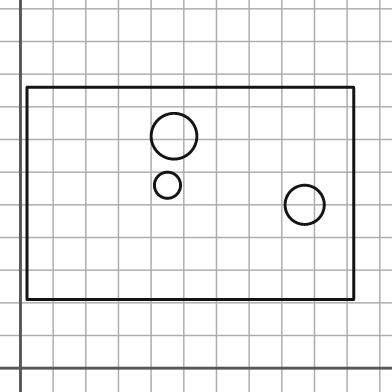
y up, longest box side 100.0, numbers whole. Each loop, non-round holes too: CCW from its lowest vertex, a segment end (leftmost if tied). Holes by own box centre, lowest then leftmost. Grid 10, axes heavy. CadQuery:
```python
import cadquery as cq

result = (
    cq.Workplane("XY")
    .moveTo(2.0, 21.0)
    .lineTo(102.0, 21.0)
    .lineTo(102.0, 86.0)
    .lineTo(2.0, 86.0)
    .close()
    .moveTo(87.0, 50.0)
    .circle(6.0)
    .moveTo(45.0, 56.0)
    .circle(4.0)
    .moveTo(47.0, 71.0)
    .circle(7.0)
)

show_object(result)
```